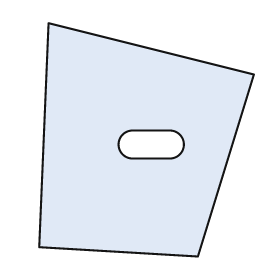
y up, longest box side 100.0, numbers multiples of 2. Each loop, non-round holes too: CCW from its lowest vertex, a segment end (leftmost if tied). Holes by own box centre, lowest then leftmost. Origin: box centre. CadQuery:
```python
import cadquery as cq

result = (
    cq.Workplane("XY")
    .moveTo(22.0, -50.0)
    .lineTo(46.0, 28.0)
    .lineTo(-42.0, 50.0)
    .lineTo(-46.0, -46.0)
    .close()
    .moveTo(-6.0, -8.0)
    .lineTo(10.0, -8.0)
    .threePointArc((16.0, -2.0), (10.0, 4.0))
    .lineTo(-6.0, 4.0)
    .threePointArc((-12.0, -2.0), (-6.0, -8.0))
    .close()
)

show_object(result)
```